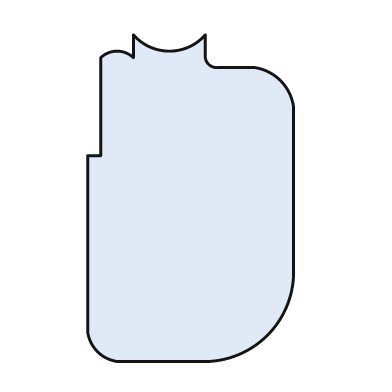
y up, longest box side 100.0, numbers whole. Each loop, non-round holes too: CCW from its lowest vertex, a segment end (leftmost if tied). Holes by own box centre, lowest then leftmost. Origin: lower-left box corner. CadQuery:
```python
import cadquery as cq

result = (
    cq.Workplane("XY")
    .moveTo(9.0, 0.0)
    .lineTo(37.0, 0.0)
    .threePointArc((55.0, 8.0), (63.0, 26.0))
    .lineTo(63.0, 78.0)
    .threePointArc((59.0, 86.0), (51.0, 90.0))
    .lineTo(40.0, 90.0)
    .threePointArc((37.0, 91.0), (36.0, 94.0))
    .lineTo(36.0, 100.0)
    .threePointArc((25.0, 95.0), (14.0, 100.0))
    .lineTo(14.0, 93.0)
    .threePointArc((9.0, 95.0), (4.0, 93.0))
    .lineTo(4.0, 63.0)
    .lineTo(0.0, 63.0)
    .lineTo(0.0, 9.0)
    .threePointArc((3.0, 3.0), (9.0, 0.0))
    .close()
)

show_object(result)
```